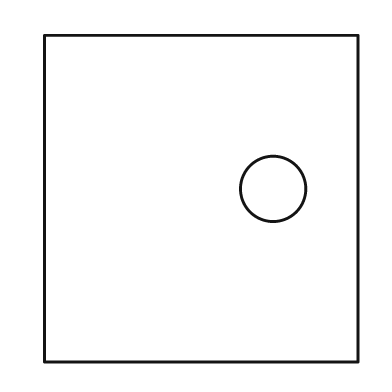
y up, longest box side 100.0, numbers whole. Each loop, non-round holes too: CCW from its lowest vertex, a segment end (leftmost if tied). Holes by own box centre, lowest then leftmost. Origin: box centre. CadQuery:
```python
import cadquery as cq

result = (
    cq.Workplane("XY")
    .moveTo(-48.0, -50.0)
    .lineTo(48.0, -50.0)
    .lineTo(48.0, 50.0)
    .lineTo(-48.0, 50.0)
    .close()
    .moveTo(22.0, 3.0)
    .circle(10.0)
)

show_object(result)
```